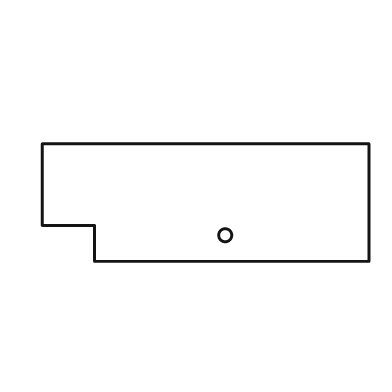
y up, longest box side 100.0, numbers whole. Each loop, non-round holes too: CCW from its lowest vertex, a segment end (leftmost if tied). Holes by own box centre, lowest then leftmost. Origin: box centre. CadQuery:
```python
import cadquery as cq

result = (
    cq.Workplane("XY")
    .moveTo(-34.0, -18.0)
    .lineTo(50.0, -18.0)
    .lineTo(50.0, 18.0)
    .lineTo(-50.0, 18.0)
    .lineTo(-50.0, -7.0)
    .lineTo(-34.0, -7.0)
    .close()
    .moveTo(6.0, -10.0)
    .circle(2.0)
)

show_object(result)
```